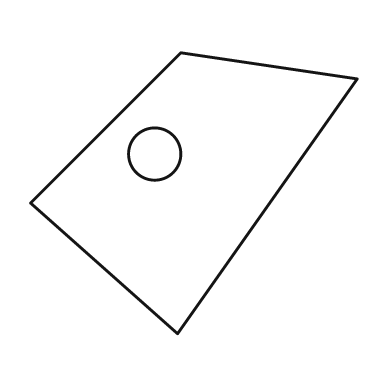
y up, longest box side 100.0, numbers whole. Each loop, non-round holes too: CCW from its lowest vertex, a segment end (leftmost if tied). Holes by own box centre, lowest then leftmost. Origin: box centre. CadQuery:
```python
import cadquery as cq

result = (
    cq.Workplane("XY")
    .moveTo(-5.0, -43.0)
    .lineTo(50.0, 35.0)
    .lineTo(-4.0, 43.0)
    .lineTo(-50.0, -3.0)
    .close()
    .moveTo(-12.0, 12.0)
    .circle(8.0)
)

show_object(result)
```